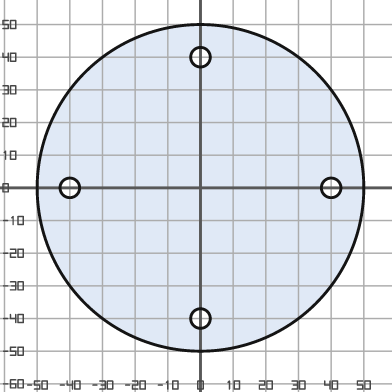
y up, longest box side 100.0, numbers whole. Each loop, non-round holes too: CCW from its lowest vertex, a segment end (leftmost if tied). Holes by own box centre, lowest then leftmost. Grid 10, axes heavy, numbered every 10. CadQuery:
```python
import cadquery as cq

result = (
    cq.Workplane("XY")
    .moveTo(0.0, 0.0)
    .circle(50.0)
    .moveTo(0.0, -40.0)
    .circle(3.0)
    .moveTo(-40.0, 0.0)
    .circle(3.0)
    .moveTo(40.0, 0.0)
    .circle(3.0)
    .moveTo(0.0, 40.0)
    .circle(3.0)
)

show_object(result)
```